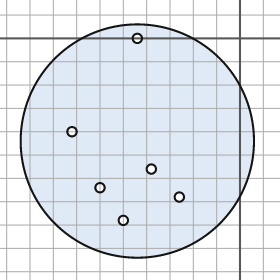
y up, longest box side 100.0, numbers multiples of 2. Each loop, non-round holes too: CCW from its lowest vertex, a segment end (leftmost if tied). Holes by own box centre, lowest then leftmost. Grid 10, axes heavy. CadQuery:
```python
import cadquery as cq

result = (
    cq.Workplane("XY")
    .moveTo(-44.0, -44.0)
    .circle(50.0)
    .moveTo(-50.0, -78.0)
    .circle(2.0)
    .moveTo(-26.0, -68.0)
    .circle(2.0)
    .moveTo(-60.0, -64.0)
    .circle(2.0)
    .moveTo(-38.0, -56.0)
    .circle(2.0)
    .moveTo(-72.0, -40.0)
    .circle(2.0)
    .moveTo(-44.0, 0.0)
    .circle(2.0)
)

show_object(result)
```